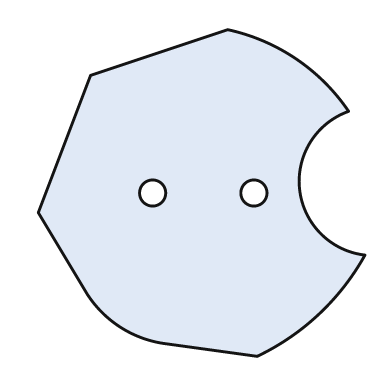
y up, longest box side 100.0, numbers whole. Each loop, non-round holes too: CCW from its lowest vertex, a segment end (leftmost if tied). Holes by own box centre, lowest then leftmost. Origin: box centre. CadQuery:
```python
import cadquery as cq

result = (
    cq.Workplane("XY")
    .moveTo(17.0, -50.0)
    .threePointArc((36.0, -37.0), (50.0, -19.0))
    .threePointArc((30.0, 1.0), (45.0, 25.0))
    .threePointArc((29.0, 41.0), (8.0, 50.0))
    .lineTo(-34.0, 36.0)
    .lineTo(-50.0, -6.0)
    .lineTo(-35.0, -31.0)
    .threePointArc((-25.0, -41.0), (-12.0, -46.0))
    .close()
    .moveTo(-15.0, 0.0)
    .circle(4.0)
    .moveTo(16.0, 0.0)
    .circle(4.0)
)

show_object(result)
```